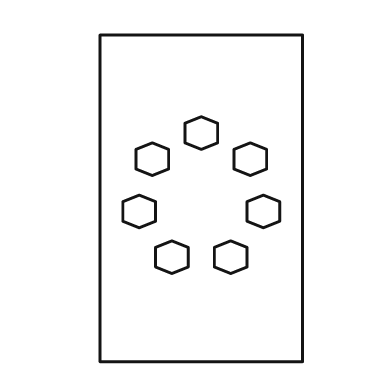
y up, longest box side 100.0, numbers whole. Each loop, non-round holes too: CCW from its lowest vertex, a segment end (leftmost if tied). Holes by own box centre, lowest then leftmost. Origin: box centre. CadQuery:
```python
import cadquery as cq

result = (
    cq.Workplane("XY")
    .moveTo(-31.0, -50.0)
    .lineTo(31.0, -50.0)
    .lineTo(31.0, 50.0)
    .lineTo(-31.0, 50.0)
    .close()
    .moveTo(-9.0, -23.0)
    .lineTo(-4.0, -21.0)
    .lineTo(-4.0, -15.0)
    .lineTo(-9.0, -13.0)
    .lineTo(-14.0, -15.0)
    .lineTo(-14.0, -21.0)
    .close()
    .moveTo(9.0, -23.0)
    .lineTo(14.0, -21.0)
    .lineTo(14.0, -15.0)
    .lineTo(9.0, -13.0)
    .lineTo(4.0, -15.0)
    .lineTo(4.0, -21.0)
    .close()
    .moveTo(-19.0, -9.0)
    .lineTo(-14.0, -7.0)
    .lineTo(-14.0, -1.0)
    .lineTo(-19.0, 1.0)
    .lineTo(-24.0, -1.0)
    .lineTo(-24.0, -7.0)
    .close()
    .moveTo(19.0, -9.0)
    .lineTo(24.0, -7.0)
    .lineTo(24.0, -1.0)
    .lineTo(19.0, 1.0)
    .lineTo(14.0, -1.0)
    .lineTo(14.0, -7.0)
    .close()
    .moveTo(-15.0, 7.0)
    .lineTo(-10.0, 9.0)
    .lineTo(-10.0, 15.0)
    .lineTo(-15.0, 17.0)
    .lineTo(-20.0, 15.0)
    .lineTo(-20.0, 9.0)
    .close()
    .moveTo(15.0, 7.0)
    .lineTo(20.0, 9.0)
    .lineTo(20.0, 15.0)
    .lineTo(15.0, 17.0)
    .lineTo(10.0, 15.0)
    .lineTo(10.0, 9.0)
    .close()
    .moveTo(0.0, 15.0)
    .lineTo(5.0, 17.0)
    .lineTo(5.0, 23.0)
    .lineTo(0.0, 25.0)
    .lineTo(-5.0, 23.0)
    .lineTo(-5.0, 17.0)
    .close()
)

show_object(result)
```